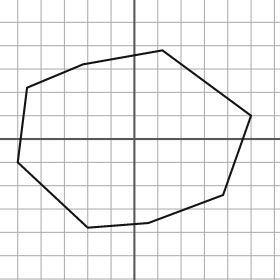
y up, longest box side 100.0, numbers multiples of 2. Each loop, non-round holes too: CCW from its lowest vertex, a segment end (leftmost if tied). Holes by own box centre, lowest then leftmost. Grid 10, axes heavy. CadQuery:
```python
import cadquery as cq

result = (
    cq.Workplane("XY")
    .moveTo(-20.0, -38.0)
    .lineTo(6.0, -36.0)
    .lineTo(38.0, -24.0)
    .lineTo(50.0, 10.0)
    .lineTo(12.0, 38.0)
    .lineTo(-22.0, 32.0)
    .lineTo(-46.0, 22.0)
    .lineTo(-50.0, -10.0)
    .close()
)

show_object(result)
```